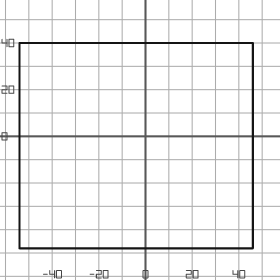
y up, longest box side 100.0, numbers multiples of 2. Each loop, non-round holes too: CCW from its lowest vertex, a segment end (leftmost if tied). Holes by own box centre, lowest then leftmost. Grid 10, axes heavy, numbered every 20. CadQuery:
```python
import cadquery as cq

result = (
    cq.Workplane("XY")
    .moveTo(-54.0, -48.0)
    .lineTo(46.0, -48.0)
    .lineTo(46.0, 40.0)
    .lineTo(-54.0, 40.0)
    .close()
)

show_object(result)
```